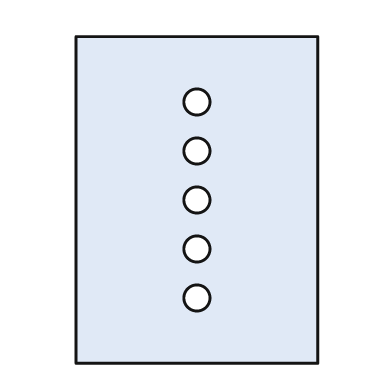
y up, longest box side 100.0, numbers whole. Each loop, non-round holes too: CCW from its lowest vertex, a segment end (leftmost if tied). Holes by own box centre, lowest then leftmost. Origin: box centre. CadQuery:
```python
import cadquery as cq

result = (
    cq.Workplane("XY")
    .moveTo(-37.0, -50.0)
    .lineTo(37.0, -50.0)
    .lineTo(37.0, 50.0)
    .lineTo(-37.0, 50.0)
    .close()
    .moveTo(0.0, -30.0)
    .circle(4.0)
    .moveTo(0.0, -15.0)
    .circle(4.0)
    .moveTo(0.0, 0.0)
    .circle(4.0)
    .moveTo(0.0, 15.0)
    .circle(4.0)
    .moveTo(0.0, 30.0)
    .circle(4.0)
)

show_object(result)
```